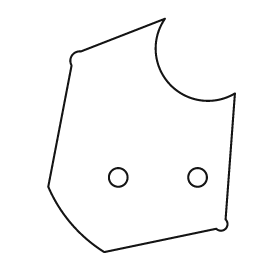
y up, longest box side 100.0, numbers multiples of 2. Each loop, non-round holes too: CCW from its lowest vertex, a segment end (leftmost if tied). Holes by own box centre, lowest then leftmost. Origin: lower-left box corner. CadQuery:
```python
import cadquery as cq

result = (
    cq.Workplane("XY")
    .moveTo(24.0, 0.0)
    .lineTo(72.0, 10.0)
    .threePointArc((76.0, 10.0), (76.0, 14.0))
    .lineTo(80.0, 68.0)
    .threePointArc((52.0, 72.0), (50.0, 100.0))
    .lineTo(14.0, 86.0)
    .threePointArc((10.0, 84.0), (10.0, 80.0))
    .lineTo(0.0, 28.0)
    .threePointArc((10.0, 12.0), (24.0, 0.0))
    .close()
    .moveTo(30.0, 32.0)
    .circle(4.0)
    .moveTo(64.0, 32.0)
    .circle(4.0)
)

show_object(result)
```